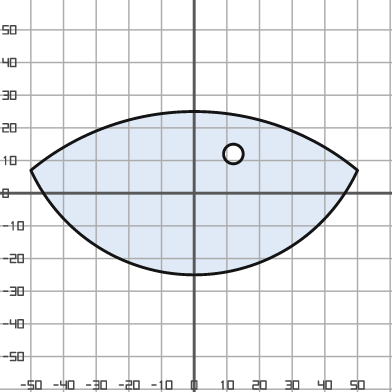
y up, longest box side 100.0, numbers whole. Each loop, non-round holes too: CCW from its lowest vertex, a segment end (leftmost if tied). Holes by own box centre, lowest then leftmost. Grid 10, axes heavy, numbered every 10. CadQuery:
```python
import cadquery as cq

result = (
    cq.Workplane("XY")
    .moveTo(-50.0, 7.0)
    .threePointArc((0.0, -25.0), (50.0, 7.0))
    .threePointArc((0.0, 25.0), (-50.0, 7.0))
    .close()
    .moveTo(12.0, 12.0)
    .circle(3.0)
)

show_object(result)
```